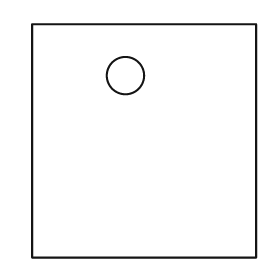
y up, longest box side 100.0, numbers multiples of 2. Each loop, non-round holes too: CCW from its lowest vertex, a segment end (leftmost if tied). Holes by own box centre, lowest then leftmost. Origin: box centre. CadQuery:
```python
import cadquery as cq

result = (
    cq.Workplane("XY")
    .moveTo(-48.0, -50.0)
    .lineTo(48.0, -50.0)
    .lineTo(48.0, 50.0)
    .lineTo(-48.0, 50.0)
    .close()
    .moveTo(-8.0, 28.0)
    .circle(8.0)
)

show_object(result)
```